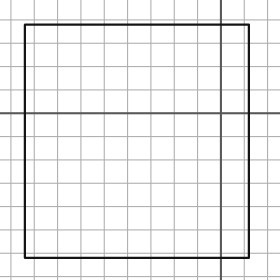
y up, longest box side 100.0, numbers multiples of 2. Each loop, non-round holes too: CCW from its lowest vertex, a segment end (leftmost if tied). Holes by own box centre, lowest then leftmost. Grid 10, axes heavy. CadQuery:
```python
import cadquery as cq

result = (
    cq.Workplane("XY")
    .moveTo(-84.0, -62.0)
    .lineTo(12.0, -62.0)
    .lineTo(12.0, 38.0)
    .lineTo(-84.0, 38.0)
    .close()
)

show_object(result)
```